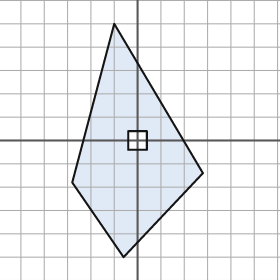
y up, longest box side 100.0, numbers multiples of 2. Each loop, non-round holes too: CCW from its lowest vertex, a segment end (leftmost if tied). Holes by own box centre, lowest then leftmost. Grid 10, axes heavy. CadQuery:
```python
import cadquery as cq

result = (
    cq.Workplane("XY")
    .moveTo(-6.0, -50.0)
    .lineTo(28.0, -14.0)
    .lineTo(-10.0, 50.0)
    .lineTo(-28.0, -18.0)
    .close()
    .moveTo(-4.0, -4.0)
    .lineTo(4.0, -4.0)
    .lineTo(4.0, 4.0)
    .lineTo(-4.0, 4.0)
    .close()
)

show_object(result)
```